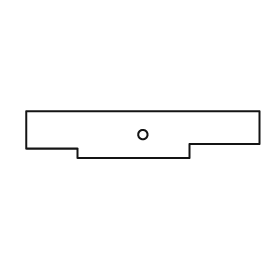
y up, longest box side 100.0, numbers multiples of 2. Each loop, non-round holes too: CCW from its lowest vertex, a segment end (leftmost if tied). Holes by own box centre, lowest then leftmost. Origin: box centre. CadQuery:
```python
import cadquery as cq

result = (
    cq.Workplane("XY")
    .moveTo(-28.0, -10.0)
    .lineTo(20.0, -10.0)
    .lineTo(20.0, -4.0)
    .lineTo(50.0, -4.0)
    .lineTo(50.0, 10.0)
    .lineTo(-50.0, 10.0)
    .lineTo(-50.0, -6.0)
    .lineTo(-28.0, -6.0)
    .close()
    .moveTo(0.0, 0.0)
    .circle(2.0)
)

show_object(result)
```